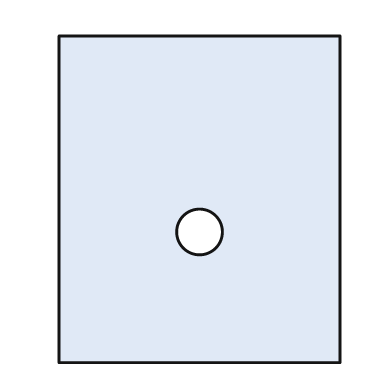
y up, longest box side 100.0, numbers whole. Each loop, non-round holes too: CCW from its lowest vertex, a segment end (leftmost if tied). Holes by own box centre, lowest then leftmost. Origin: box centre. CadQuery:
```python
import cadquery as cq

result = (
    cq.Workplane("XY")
    .moveTo(-43.0, -50.0)
    .lineTo(43.0, -50.0)
    .lineTo(43.0, 50.0)
    .lineTo(-43.0, 50.0)
    .close()
    .moveTo(0.0, -10.0)
    .circle(7.0)
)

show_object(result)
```